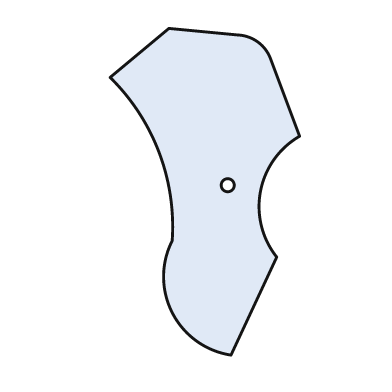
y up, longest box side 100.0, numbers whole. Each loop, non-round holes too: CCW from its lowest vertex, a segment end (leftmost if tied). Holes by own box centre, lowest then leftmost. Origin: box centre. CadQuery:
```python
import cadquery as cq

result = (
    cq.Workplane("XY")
    .moveTo(8.0, -50.0)
    .lineTo(22.0, -20.0)
    .threePointArc((17.0, 0.0), (29.0, 17.0))
    .lineTo(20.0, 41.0)
    .threePointArc((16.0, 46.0), (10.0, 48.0))
    .lineTo(-11.0, 50.0)
    .lineTo(-29.0, 35.0)
    .threePointArc((-14.0, 12.0), (-10.0, -15.0))
    .threePointArc((-10.0, -37.0), (8.0, -50.0))
    .close()
    .moveTo(7.0, 2.0)
    .circle(2.0)
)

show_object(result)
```